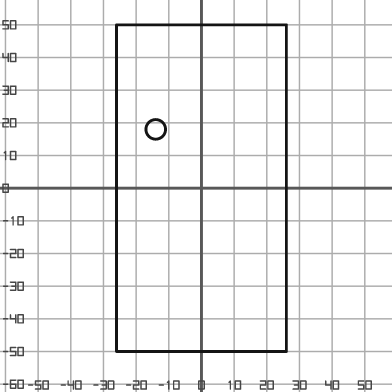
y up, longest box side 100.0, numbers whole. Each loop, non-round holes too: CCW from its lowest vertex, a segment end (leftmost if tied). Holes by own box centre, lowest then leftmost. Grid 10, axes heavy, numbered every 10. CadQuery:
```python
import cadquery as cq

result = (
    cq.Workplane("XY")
    .moveTo(-26.0, -50.0)
    .lineTo(26.0, -50.0)
    .lineTo(26.0, 50.0)
    .lineTo(-26.0, 50.0)
    .close()
    .moveTo(-14.0, 18.0)
    .circle(3.0)
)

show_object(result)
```